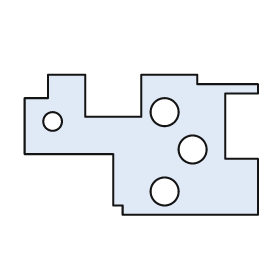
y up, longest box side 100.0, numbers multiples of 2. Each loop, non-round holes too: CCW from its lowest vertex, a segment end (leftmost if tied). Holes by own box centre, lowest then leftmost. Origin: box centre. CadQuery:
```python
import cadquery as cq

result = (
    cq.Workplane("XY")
    .moveTo(-8.0, -30.0)
    .lineTo(50.0, -30.0)
    .lineTo(50.0, -6.0)
    .lineTo(36.0, -6.0)
    .lineTo(36.0, 22.0)
    .lineTo(50.0, 22.0)
    .lineTo(50.0, 26.0)
    .lineTo(24.0, 26.0)
    .lineTo(24.0, 30.0)
    .lineTo(0.0, 30.0)
    .lineTo(0.0, 12.0)
    .lineTo(-24.0, 12.0)
    .lineTo(-24.0, 30.0)
    .lineTo(-40.0, 30.0)
    .lineTo(-40.0, 20.0)
    .lineTo(-50.0, 20.0)
    .lineTo(-50.0, -4.0)
    .lineTo(-12.0, -4.0)
    .lineTo(-12.0, -26.0)
    .lineTo(-8.0, -26.0)
    .close()
    .moveTo(10.0, -20.0)
    .circle(6.0)
    .moveTo(22.0, -2.0)
    .circle(6.0)
    .moveTo(-38.0, 10.0)
    .circle(4.0)
    .moveTo(10.0, 14.0)
    .circle(6.0)
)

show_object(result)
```